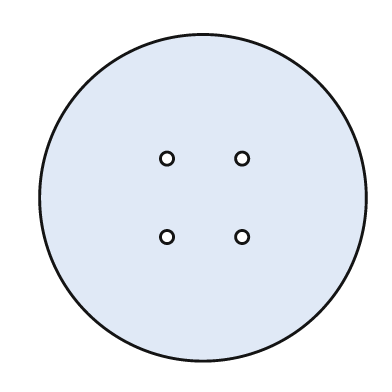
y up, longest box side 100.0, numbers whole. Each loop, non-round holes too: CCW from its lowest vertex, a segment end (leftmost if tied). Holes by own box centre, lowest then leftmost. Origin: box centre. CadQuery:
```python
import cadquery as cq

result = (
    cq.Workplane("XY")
    .moveTo(0.0, 0.0)
    .circle(50.0)
    .moveTo(-11.0, -12.0)
    .circle(2.0)
    .moveTo(12.0, -12.0)
    .circle(2.0)
    .moveTo(-11.0, 12.0)
    .circle(2.0)
    .moveTo(12.0, 12.0)
    .circle(2.0)
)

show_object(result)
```